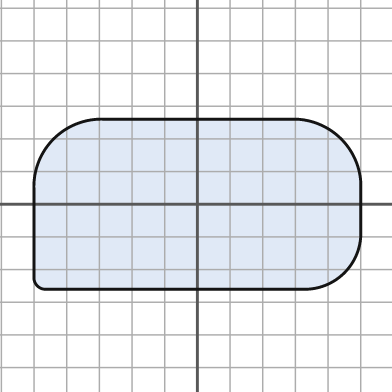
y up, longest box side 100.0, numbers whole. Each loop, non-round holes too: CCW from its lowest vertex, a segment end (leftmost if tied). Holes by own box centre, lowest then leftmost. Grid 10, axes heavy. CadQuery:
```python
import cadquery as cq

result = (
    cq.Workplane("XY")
    .moveTo(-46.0, -26.0)
    .lineTo(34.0, -26.0)
    .threePointArc((45.0, -21.0), (50.0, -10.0))
    .lineTo(50.0, 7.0)
    .threePointArc((44.0, 20.0), (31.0, 26.0))
    .lineTo(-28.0, 26.0)
    .threePointArc((-44.0, 20.0), (-50.0, 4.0))
    .lineTo(-50.0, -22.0)
    .threePointArc((-49.0, -25.0), (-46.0, -26.0))
    .close()
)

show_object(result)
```